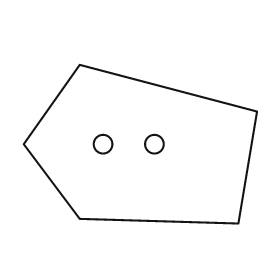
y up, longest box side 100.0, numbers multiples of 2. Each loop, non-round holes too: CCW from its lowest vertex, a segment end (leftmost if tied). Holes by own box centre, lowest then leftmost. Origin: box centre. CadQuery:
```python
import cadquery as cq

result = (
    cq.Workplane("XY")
    .moveTo(42.0, -34.0)
    .lineTo(50.0, 14.0)
    .lineTo(-26.0, 34.0)
    .lineTo(-50.0, 0.0)
    .lineTo(-26.0, -32.0)
    .close()
    .moveTo(-16.0, 0.0)
    .circle(4.0)
    .moveTo(6.0, 0.0)
    .circle(4.0)
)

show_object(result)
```